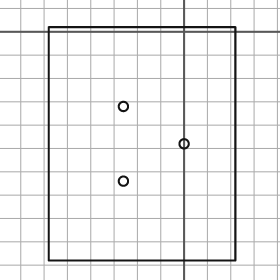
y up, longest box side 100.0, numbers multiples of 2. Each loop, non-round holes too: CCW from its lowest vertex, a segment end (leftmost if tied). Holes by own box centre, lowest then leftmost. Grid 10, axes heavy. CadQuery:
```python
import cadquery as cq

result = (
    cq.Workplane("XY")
    .moveTo(-58.0, -98.0)
    .lineTo(22.0, -98.0)
    .lineTo(22.0, 2.0)
    .lineTo(-58.0, 2.0)
    .close()
    .moveTo(-26.0, -64.0)
    .circle(2.0)
    .moveTo(0.0, -48.0)
    .circle(2.0)
    .moveTo(-26.0, -32.0)
    .circle(2.0)
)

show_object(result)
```